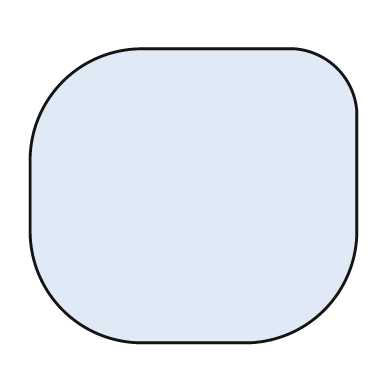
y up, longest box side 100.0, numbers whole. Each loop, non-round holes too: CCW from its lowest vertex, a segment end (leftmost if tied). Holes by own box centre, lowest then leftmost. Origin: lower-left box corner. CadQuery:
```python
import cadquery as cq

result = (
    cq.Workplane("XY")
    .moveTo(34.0, 0.0)
    .lineTo(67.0, 0.0)
    .threePointArc((90.0, 10.0), (100.0, 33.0))
    .lineTo(100.0, 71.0)
    .threePointArc((94.0, 84.0), (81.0, 90.0))
    .lineTo(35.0, 90.0)
    .threePointArc((10.0, 80.0), (0.0, 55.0))
    .lineTo(0.0, 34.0)
    .threePointArc((10.0, 10.0), (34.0, 0.0))
    .close()
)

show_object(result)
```